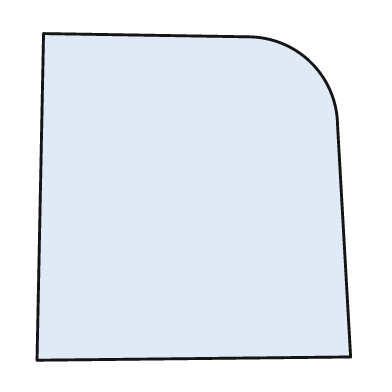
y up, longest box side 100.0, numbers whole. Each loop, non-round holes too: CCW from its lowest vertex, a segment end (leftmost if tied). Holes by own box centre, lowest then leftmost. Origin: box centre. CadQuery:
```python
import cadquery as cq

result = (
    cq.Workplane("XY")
    .moveTo(-48.0, -50.0)
    .lineTo(48.0, -49.0)
    .lineTo(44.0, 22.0)
    .threePointArc((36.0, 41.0), (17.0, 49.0))
    .lineTo(-46.0, 50.0)
    .close()
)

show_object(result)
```